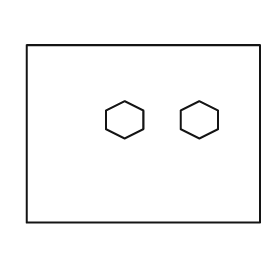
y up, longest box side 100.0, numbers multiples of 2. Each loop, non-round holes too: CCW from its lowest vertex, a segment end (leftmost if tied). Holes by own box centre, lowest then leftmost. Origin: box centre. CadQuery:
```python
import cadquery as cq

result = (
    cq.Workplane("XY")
    .moveTo(-50.0, -38.0)
    .lineTo(50.0, -38.0)
    .lineTo(50.0, 38.0)
    .lineTo(-50.0, 38.0)
    .close()
    .moveTo(-8.0, -2.0)
    .lineTo(0.0, 2.0)
    .lineTo(0.0, 10.0)
    .lineTo(-8.0, 14.0)
    .lineTo(-16.0, 10.0)
    .lineTo(-16.0, 2.0)
    .close()
    .moveTo(24.0, -2.0)
    .lineTo(32.0, 2.0)
    .lineTo(32.0, 10.0)
    .lineTo(24.0, 14.0)
    .lineTo(16.0, 10.0)
    .lineTo(16.0, 2.0)
    .close()
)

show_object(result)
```